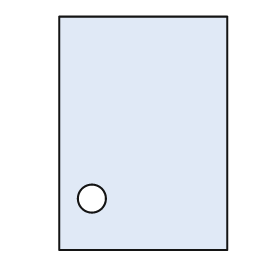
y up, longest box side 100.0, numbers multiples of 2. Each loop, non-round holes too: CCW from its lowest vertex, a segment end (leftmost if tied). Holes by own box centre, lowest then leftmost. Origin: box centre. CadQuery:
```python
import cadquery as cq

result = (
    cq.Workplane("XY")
    .moveTo(-36.0, -50.0)
    .lineTo(36.0, -50.0)
    .lineTo(36.0, 50.0)
    .lineTo(-36.0, 50.0)
    .close()
    .moveTo(-22.0, -28.0)
    .circle(6.0)
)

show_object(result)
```